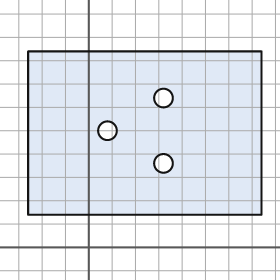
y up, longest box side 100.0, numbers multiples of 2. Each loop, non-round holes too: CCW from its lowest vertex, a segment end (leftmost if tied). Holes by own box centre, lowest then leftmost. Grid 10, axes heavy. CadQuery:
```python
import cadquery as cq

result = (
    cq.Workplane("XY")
    .moveTo(-26.0, 14.0)
    .lineTo(74.0, 14.0)
    .lineTo(74.0, 84.0)
    .lineTo(-26.0, 84.0)
    .close()
    .moveTo(32.0, 36.0)
    .circle(4.0)
    .moveTo(8.0, 50.0)
    .circle(4.0)
    .moveTo(32.0, 64.0)
    .circle(4.0)
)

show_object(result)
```